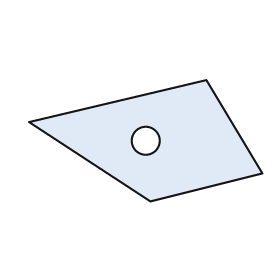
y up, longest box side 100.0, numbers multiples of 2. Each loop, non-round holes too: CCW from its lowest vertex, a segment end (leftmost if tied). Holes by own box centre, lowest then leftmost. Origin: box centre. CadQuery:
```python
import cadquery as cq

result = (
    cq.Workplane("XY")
    .moveTo(2.0, -26.0)
    .lineTo(50.0, -14.0)
    .lineTo(26.0, 26.0)
    .lineTo(-50.0, 8.0)
    .close()
    .moveTo(0.0, 0.0)
    .circle(6.0)
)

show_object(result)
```